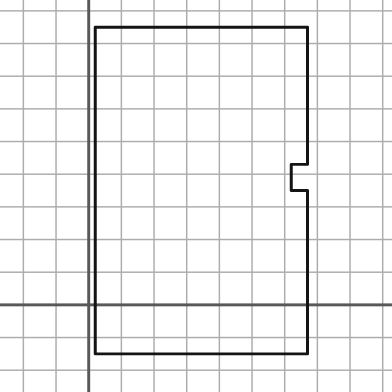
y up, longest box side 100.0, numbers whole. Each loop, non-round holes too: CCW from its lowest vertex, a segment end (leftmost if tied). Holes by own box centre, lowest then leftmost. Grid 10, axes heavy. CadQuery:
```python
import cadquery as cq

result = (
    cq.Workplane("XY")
    .moveTo(2.0, -15.0)
    .lineTo(67.0, -15.0)
    .lineTo(67.0, 35.0)
    .lineTo(62.0, 35.0)
    .lineTo(62.0, 43.0)
    .lineTo(67.0, 43.0)
    .lineTo(67.0, 85.0)
    .lineTo(2.0, 85.0)
    .close()
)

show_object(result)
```